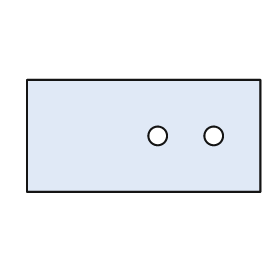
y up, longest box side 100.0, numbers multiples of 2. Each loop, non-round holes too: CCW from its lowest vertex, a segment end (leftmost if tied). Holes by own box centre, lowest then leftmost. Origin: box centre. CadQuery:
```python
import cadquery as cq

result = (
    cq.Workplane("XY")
    .moveTo(-50.0, -24.0)
    .lineTo(50.0, -24.0)
    .lineTo(50.0, 24.0)
    .lineTo(-50.0, 24.0)
    .close()
    .moveTo(6.0, 0.0)
    .circle(4.0)
    .moveTo(30.0, 0.0)
    .circle(4.0)
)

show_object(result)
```